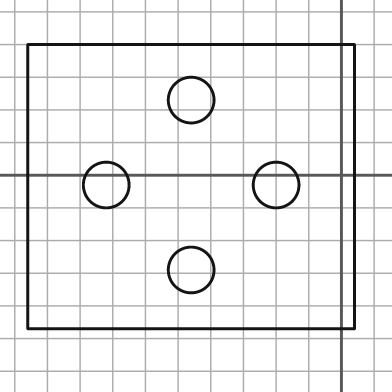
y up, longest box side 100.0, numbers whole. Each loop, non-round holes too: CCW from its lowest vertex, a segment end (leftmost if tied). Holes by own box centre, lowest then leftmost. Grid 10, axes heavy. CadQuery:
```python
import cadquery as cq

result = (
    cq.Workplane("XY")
    .moveTo(-96.0, -47.0)
    .lineTo(4.0, -47.0)
    .lineTo(4.0, 40.0)
    .lineTo(-96.0, 40.0)
    .close()
    .moveTo(-46.0, -29.0)
    .circle(7.0)
    .moveTo(-72.0, -3.0)
    .circle(7.0)
    .moveTo(-20.0, -3.0)
    .circle(7.0)
    .moveTo(-46.0, 23.0)
    .circle(7.0)
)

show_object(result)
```